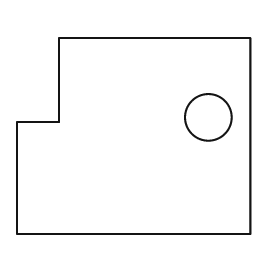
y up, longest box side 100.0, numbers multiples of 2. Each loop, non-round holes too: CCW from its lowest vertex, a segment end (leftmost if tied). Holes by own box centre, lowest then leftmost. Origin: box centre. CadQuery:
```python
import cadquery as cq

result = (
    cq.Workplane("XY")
    .moveTo(-50.0, -42.0)
    .lineTo(50.0, -42.0)
    .lineTo(50.0, 42.0)
    .lineTo(-32.0, 42.0)
    .lineTo(-32.0, 6.0)
    .lineTo(-50.0, 6.0)
    .close()
    .moveTo(32.0, 8.0)
    .circle(10.0)
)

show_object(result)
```